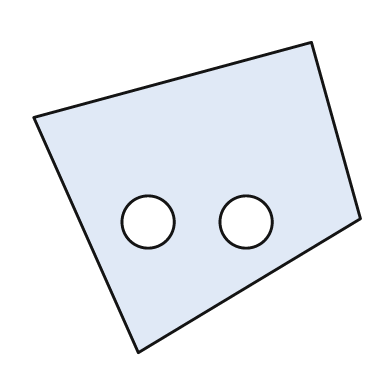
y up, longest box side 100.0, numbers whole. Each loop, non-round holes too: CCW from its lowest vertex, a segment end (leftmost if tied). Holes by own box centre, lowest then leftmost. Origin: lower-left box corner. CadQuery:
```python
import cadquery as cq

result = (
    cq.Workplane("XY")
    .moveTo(32.0, 0.0)
    .lineTo(100.0, 41.0)
    .lineTo(85.0, 95.0)
    .lineTo(0.0, 72.0)
    .close()
    .moveTo(35.0, 40.0)
    .circle(8.0)
    .moveTo(65.0, 40.0)
    .circle(8.0)
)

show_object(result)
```